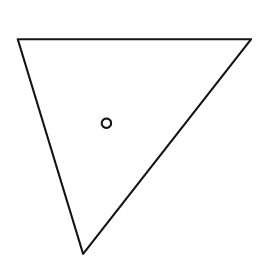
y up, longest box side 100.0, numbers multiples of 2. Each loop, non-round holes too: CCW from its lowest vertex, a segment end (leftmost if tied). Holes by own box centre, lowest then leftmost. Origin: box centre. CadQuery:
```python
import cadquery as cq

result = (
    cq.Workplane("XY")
    .moveTo(-22.0, -46.0)
    .lineTo(50.0, 46.0)
    .lineTo(-50.0, 46.0)
    .close()
    .moveTo(-12.0, 10.0)
    .circle(2.0)
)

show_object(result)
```